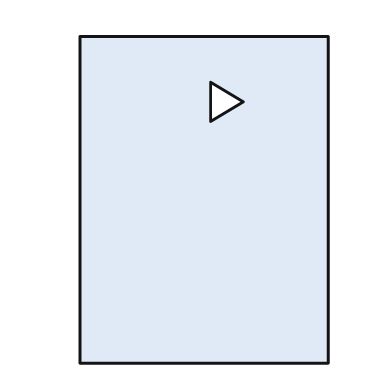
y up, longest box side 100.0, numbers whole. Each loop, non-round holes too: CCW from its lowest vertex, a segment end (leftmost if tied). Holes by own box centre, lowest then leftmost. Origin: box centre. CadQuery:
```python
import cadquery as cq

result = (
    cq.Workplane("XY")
    .moveTo(-38.0, -50.0)
    .lineTo(38.0, -50.0)
    .lineTo(38.0, 50.0)
    .lineTo(-38.0, 50.0)
    .close()
    .moveTo(2.0, 24.0)
    .lineTo(12.0, 30.0)
    .lineTo(2.0, 36.0)
    .close()
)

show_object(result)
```